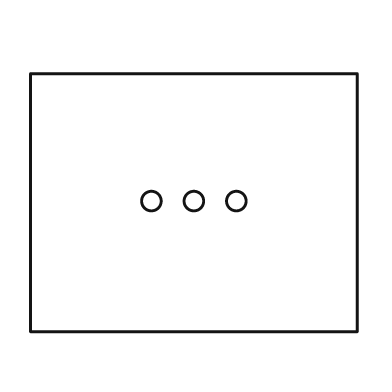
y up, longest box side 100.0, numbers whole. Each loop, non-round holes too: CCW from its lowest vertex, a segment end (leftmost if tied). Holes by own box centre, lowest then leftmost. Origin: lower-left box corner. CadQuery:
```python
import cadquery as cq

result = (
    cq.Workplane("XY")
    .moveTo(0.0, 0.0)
    .lineTo(100.0, 0.0)
    .lineTo(100.0, 79.0)
    .lineTo(0.0, 79.0)
    .close()
    .moveTo(37.0, 40.0)
    .circle(3.0)
    .moveTo(50.0, 40.0)
    .circle(3.0)
    .moveTo(63.0, 40.0)
    .circle(3.0)
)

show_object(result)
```